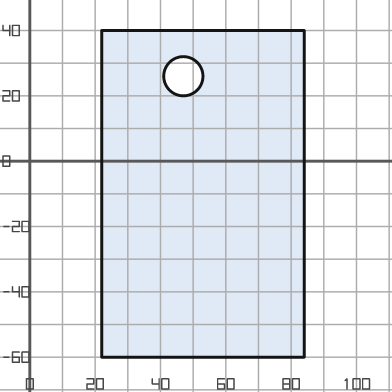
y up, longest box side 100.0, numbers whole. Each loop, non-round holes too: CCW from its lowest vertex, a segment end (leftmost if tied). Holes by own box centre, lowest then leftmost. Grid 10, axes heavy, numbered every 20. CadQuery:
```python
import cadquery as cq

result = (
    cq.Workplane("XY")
    .moveTo(22.0, -60.0)
    .lineTo(84.0, -60.0)
    .lineTo(84.0, 40.0)
    .lineTo(22.0, 40.0)
    .close()
    .moveTo(47.0, 26.0)
    .circle(6.0)
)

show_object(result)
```